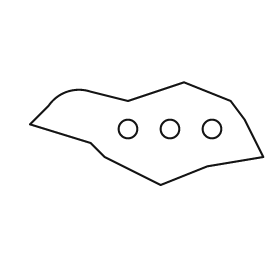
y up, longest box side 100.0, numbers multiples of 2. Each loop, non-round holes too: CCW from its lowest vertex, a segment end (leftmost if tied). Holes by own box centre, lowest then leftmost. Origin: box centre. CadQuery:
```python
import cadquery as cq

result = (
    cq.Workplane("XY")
    .moveTo(6.0, -22.0)
    .lineTo(26.0, -14.0)
    .lineTo(50.0, -10.0)
    .lineTo(42.0, 6.0)
    .lineTo(36.0, 14.0)
    .lineTo(16.0, 22.0)
    .lineTo(-8.0, 14.0)
    .lineTo(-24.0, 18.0)
    .threePointArc((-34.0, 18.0), (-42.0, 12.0))
    .lineTo(-50.0, 4.0)
    .lineTo(-24.0, -4.0)
    .lineTo(-18.0, -10.0)
    .close()
    .moveTo(-8.0, 2.0)
    .circle(4.0)
    .moveTo(10.0, 2.0)
    .circle(4.0)
    .moveTo(28.0, 2.0)
    .circle(4.0)
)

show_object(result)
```